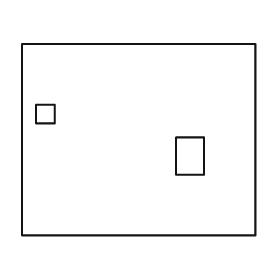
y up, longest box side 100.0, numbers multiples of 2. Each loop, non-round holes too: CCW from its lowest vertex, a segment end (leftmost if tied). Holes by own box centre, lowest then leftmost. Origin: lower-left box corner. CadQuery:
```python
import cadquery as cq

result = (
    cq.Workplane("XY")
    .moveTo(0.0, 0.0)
    .lineTo(100.0, 0.0)
    .lineTo(100.0, 82.0)
    .lineTo(0.0, 82.0)
    .close()
    .moveTo(66.0, 26.0)
    .lineTo(78.0, 26.0)
    .lineTo(78.0, 42.0)
    .lineTo(66.0, 42.0)
    .close()
    .moveTo(6.0, 48.0)
    .lineTo(14.0, 48.0)
    .lineTo(14.0, 56.0)
    .lineTo(6.0, 56.0)
    .close()
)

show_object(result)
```